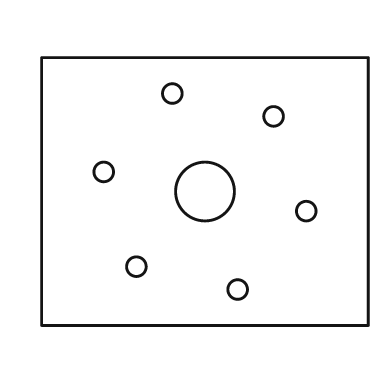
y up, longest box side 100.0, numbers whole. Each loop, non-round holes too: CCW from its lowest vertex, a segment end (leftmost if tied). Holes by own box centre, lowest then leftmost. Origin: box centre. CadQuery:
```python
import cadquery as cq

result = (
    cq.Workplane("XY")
    .moveTo(-50.0, -41.0)
    .lineTo(50.0, -41.0)
    .lineTo(50.0, 41.0)
    .lineTo(-50.0, 41.0)
    .close()
    .moveTo(10.0, -30.0)
    .circle(3.0)
    .moveTo(-21.0, -23.0)
    .circle(3.0)
    .moveTo(31.0, -6.0)
    .circle(3.0)
    .moveTo(0.0, 0.0)
    .circle(9.0)
    .moveTo(-31.0, 6.0)
    .circle(3.0)
    .moveTo(21.0, 23.0)
    .circle(3.0)
    .moveTo(-10.0, 30.0)
    .circle(3.0)
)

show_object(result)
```